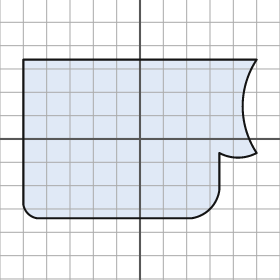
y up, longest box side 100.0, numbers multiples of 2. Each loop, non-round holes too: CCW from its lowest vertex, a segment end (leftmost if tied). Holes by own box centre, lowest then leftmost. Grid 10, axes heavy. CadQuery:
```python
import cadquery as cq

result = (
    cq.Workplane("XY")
    .moveTo(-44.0, -34.0)
    .lineTo(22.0, -34.0)
    .threePointArc((30.0, -30.0), (34.0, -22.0))
    .lineTo(34.0, -6.0)
    .threePointArc((42.0, -8.0), (50.0, -6.0))
    .threePointArc((44.0, 14.0), (50.0, 34.0))
    .lineTo(-50.0, 34.0)
    .lineTo(-50.0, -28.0)
    .threePointArc((-48.0, -32.0), (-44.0, -34.0))
    .close()
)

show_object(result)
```